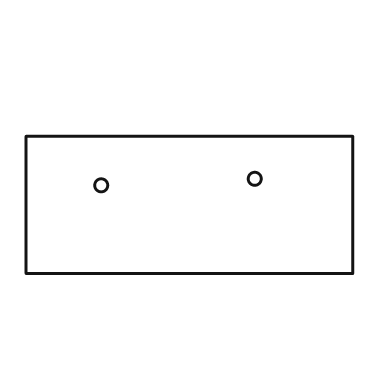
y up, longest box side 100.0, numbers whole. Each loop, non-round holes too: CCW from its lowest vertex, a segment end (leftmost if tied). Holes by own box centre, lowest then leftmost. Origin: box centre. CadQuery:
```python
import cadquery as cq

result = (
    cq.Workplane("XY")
    .moveTo(-50.0, -21.0)
    .lineTo(50.0, -21.0)
    .lineTo(50.0, 21.0)
    .lineTo(-50.0, 21.0)
    .close()
    .moveTo(-27.0, 6.0)
    .circle(2.0)
    .moveTo(20.0, 8.0)
    .circle(2.0)
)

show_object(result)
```